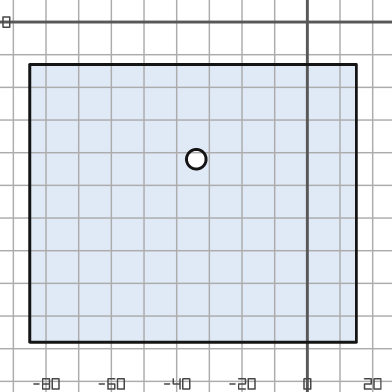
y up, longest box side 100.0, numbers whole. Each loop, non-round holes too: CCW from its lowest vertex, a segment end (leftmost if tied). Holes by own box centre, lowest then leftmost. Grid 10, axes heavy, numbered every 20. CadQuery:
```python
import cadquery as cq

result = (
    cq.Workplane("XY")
    .moveTo(-85.0, -98.0)
    .lineTo(15.0, -98.0)
    .lineTo(15.0, -13.0)
    .lineTo(-85.0, -13.0)
    .close()
    .moveTo(-34.0, -42.0)
    .circle(3.0)
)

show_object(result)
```